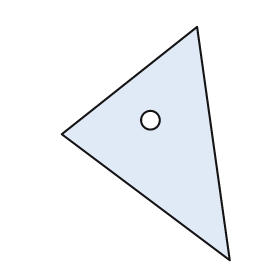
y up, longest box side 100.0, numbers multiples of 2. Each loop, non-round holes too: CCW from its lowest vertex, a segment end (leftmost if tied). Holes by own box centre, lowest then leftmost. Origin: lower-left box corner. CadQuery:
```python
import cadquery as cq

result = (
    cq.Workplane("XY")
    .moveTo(72.0, 0.0)
    .lineTo(58.0, 100.0)
    .lineTo(0.0, 54.0)
    .close()
    .moveTo(38.0, 60.0)
    .circle(4.0)
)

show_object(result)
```